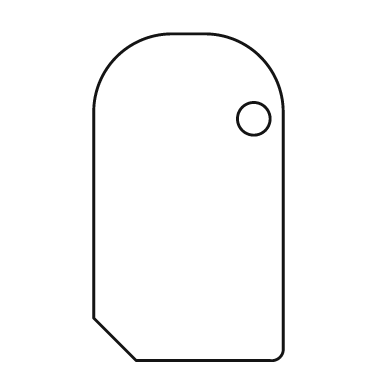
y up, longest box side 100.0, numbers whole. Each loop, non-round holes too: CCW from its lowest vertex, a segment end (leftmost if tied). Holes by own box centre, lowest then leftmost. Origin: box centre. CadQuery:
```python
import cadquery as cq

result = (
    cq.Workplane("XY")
    .moveTo(-16.0, -50.0)
    .lineTo(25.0, -50.0)
    .threePointArc((28.0, -49.0), (29.0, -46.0))
    .lineTo(29.0, 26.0)
    .threePointArc((22.0, 43.0), (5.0, 50.0))
    .lineTo(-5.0, 50.0)
    .threePointArc((-22.0, 43.0), (-29.0, 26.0))
    .lineTo(-29.0, -37.0)
    .close()
    .moveTo(20.0, 24.0)
    .circle(5.0)
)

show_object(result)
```